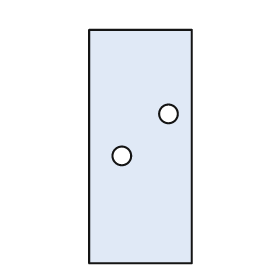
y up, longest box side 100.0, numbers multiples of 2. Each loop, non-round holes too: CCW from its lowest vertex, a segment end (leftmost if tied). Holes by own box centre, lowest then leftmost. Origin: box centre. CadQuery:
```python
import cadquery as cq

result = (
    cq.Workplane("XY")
    .moveTo(-22.0, -50.0)
    .lineTo(22.0, -50.0)
    .lineTo(22.0, 50.0)
    .lineTo(-22.0, 50.0)
    .close()
    .moveTo(-8.0, -4.0)
    .circle(4.0)
    .moveTo(12.0, 14.0)
    .circle(4.0)
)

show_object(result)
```